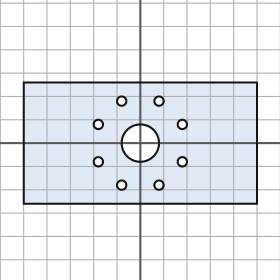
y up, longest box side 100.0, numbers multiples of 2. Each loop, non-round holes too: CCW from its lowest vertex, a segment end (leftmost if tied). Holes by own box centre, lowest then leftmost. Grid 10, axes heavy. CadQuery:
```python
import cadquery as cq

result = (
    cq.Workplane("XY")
    .moveTo(-50.0, -26.0)
    .lineTo(50.0, -26.0)
    .lineTo(50.0, 26.0)
    .lineTo(-50.0, 26.0)
    .close()
    .moveTo(-8.0, -18.0)
    .circle(2.0)
    .moveTo(8.0, -18.0)
    .circle(2.0)
    .moveTo(-18.0, -8.0)
    .circle(2.0)
    .moveTo(18.0, -8.0)
    .circle(2.0)
    .moveTo(0.0, 0.0)
    .circle(8.0)
    .moveTo(-18.0, 8.0)
    .circle(2.0)
    .moveTo(18.0, 8.0)
    .circle(2.0)
    .moveTo(-8.0, 18.0)
    .circle(2.0)
    .moveTo(8.0, 18.0)
    .circle(2.0)
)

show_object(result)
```